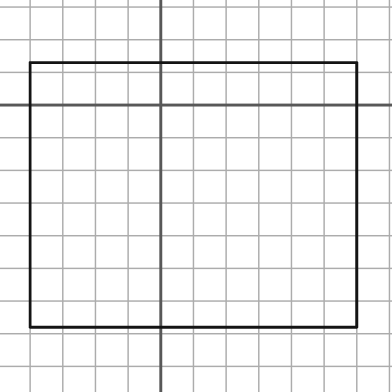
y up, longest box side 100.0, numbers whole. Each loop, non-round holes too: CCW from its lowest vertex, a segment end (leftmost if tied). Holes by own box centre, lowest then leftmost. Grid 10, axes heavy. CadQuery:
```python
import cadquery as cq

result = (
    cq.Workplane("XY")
    .moveTo(-40.0, -68.0)
    .lineTo(60.0, -68.0)
    .lineTo(60.0, 13.0)
    .lineTo(-40.0, 13.0)
    .close()
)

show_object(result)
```